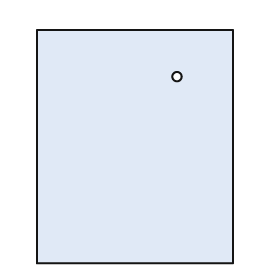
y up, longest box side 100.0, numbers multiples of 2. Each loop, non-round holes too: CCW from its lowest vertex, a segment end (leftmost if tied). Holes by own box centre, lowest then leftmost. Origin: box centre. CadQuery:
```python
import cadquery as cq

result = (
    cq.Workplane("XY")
    .moveTo(-42.0, -50.0)
    .lineTo(42.0, -50.0)
    .lineTo(42.0, 50.0)
    .lineTo(-42.0, 50.0)
    .close()
    .moveTo(18.0, 30.0)
    .circle(2.0)
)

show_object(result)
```